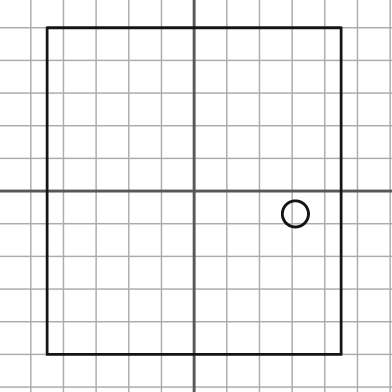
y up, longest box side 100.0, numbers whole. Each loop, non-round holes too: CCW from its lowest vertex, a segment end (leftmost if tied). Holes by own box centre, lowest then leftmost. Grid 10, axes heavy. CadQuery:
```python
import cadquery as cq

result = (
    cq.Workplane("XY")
    .moveTo(-45.0, -50.0)
    .lineTo(45.0, -50.0)
    .lineTo(45.0, 50.0)
    .lineTo(-45.0, 50.0)
    .close()
    .moveTo(31.0, -7.0)
    .circle(4.0)
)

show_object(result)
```